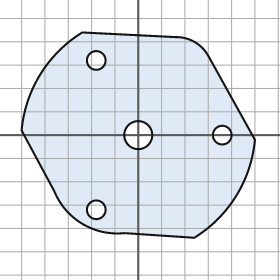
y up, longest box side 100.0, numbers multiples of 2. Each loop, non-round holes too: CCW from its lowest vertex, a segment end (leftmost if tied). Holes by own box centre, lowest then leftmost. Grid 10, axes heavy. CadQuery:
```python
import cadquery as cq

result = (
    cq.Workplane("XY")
    .moveTo(24.0, -44.0)
    .threePointArc((42.0, -26.0), (50.0, -2.0))
    .lineTo(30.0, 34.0)
    .threePointArc((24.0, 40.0), (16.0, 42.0))
    .lineTo(-24.0, 44.0)
    .threePointArc((-42.0, 26.0), (-50.0, 2.0))
    .lineTo(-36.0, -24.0)
    .threePointArc((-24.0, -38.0), (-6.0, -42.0))
    .close()
    .moveTo(-18.0, -32.0)
    .circle(4.0)
    .moveTo(0.0, 0.0)
    .circle(6.0)
    .moveTo(36.0, 0.0)
    .circle(4.0)
    .moveTo(-18.0, 32.0)
    .circle(4.0)
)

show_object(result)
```